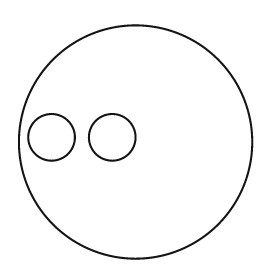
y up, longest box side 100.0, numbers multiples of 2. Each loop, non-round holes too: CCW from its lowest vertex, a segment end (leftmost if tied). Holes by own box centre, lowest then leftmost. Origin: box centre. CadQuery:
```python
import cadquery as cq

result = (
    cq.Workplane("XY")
    .moveTo(0.0, 0.0)
    .circle(50.0)
    .moveTo(-36.0, 2.0)
    .circle(10.0)
    .moveTo(-10.0, 2.0)
    .circle(10.0)
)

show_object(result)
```